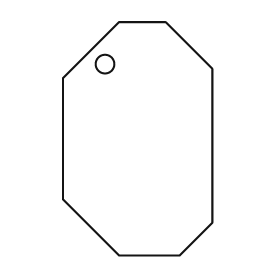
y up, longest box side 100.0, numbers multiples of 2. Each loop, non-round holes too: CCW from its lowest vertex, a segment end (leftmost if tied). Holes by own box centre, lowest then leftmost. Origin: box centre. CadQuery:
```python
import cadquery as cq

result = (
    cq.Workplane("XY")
    .moveTo(-8.0, -50.0)
    .lineTo(18.0, -50.0)
    .lineTo(32.0, -36.0)
    .lineTo(32.0, 30.0)
    .lineTo(12.0, 50.0)
    .lineTo(-8.0, 50.0)
    .lineTo(-32.0, 26.0)
    .lineTo(-32.0, -26.0)
    .close()
    .moveTo(-14.0, 32.0)
    .circle(4.0)
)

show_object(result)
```